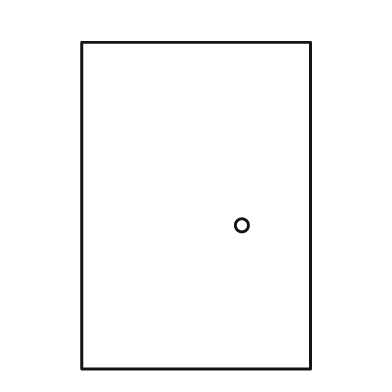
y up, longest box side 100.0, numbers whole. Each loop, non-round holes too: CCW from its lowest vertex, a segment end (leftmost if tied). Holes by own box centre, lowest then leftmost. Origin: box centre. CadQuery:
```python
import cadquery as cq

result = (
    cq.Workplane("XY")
    .moveTo(-35.0, -50.0)
    .lineTo(35.0, -50.0)
    .lineTo(35.0, 50.0)
    .lineTo(-35.0, 50.0)
    .close()
    .moveTo(14.0, -6.0)
    .circle(2.0)
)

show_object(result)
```